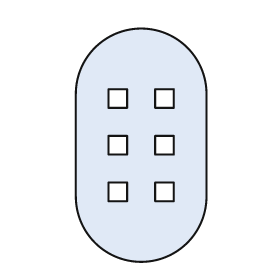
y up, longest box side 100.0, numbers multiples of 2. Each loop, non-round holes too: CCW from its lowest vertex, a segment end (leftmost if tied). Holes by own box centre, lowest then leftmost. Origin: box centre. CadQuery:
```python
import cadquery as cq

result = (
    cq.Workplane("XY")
    .moveTo(-28.0, -22.0)
    .threePointArc((0.0, -50.0), (28.0, -22.0))
    .lineTo(28.0, 22.0)
    .threePointArc((0.0, 50.0), (-28.0, 22.0))
    .close()
    .moveTo(-14.0, -24.0)
    .lineTo(-6.0, -24.0)
    .lineTo(-6.0, -16.0)
    .lineTo(-14.0, -16.0)
    .close()
    .moveTo(6.0, -24.0)
    .lineTo(14.0, -24.0)
    .lineTo(14.0, -16.0)
    .lineTo(6.0, -16.0)
    .close()
    .moveTo(-14.0, -4.0)
    .lineTo(-6.0, -4.0)
    .lineTo(-6.0, 4.0)
    .lineTo(-14.0, 4.0)
    .close()
    .moveTo(6.0, -4.0)
    .lineTo(14.0, -4.0)
    .lineTo(14.0, 4.0)
    .lineTo(6.0, 4.0)
    .close()
    .moveTo(-14.0, 16.0)
    .lineTo(-6.0, 16.0)
    .lineTo(-6.0, 24.0)
    .lineTo(-14.0, 24.0)
    .close()
    .moveTo(6.0, 16.0)
    .lineTo(14.0, 16.0)
    .lineTo(14.0, 24.0)
    .lineTo(6.0, 24.0)
    .close()
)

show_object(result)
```